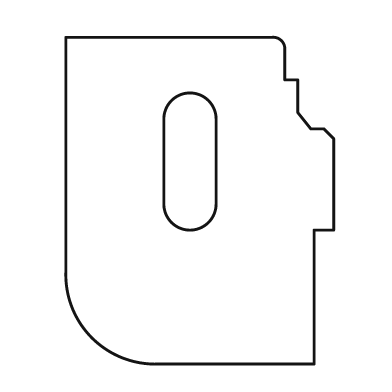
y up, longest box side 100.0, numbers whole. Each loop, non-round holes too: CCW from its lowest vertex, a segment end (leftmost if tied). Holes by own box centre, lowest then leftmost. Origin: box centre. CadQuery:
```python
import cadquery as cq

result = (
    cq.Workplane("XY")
    .moveTo(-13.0, -50.0)
    .lineTo(35.0, -50.0)
    .lineTo(35.0, -9.0)
    .lineTo(41.0, -9.0)
    .lineTo(41.0, 19.0)
    .lineTo(38.0, 22.0)
    .lineTo(34.0, 22.0)
    .lineTo(30.0, 27.0)
    .lineTo(30.0, 37.0)
    .lineTo(26.0, 37.0)
    .lineTo(26.0, 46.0)
    .threePointArc((25.0, 49.0), (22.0, 50.0))
    .lineTo(-41.0, 50.0)
    .lineTo(-41.0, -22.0)
    .threePointArc((-33.0, -42.0), (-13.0, -50.0))
    .close()
    .moveTo(-11.0, -1.0)
    .threePointArc((-3.0, -9.0), (5.0, -1.0))
    .lineTo(5.0, 25.0)
    .threePointArc((-3.0, 33.0), (-11.0, 25.0))
    .close()
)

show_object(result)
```